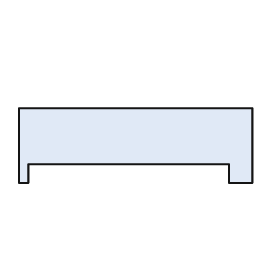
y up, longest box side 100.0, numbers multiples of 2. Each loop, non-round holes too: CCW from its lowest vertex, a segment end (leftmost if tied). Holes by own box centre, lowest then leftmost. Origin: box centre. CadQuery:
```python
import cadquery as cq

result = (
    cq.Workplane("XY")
    .moveTo(-50.0, -16.0)
    .lineTo(-46.0, -16.0)
    .lineTo(-46.0, -8.0)
    .lineTo(40.0, -8.0)
    .lineTo(40.0, -16.0)
    .lineTo(50.0, -16.0)
    .lineTo(50.0, 16.0)
    .lineTo(-50.0, 16.0)
    .close()
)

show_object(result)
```